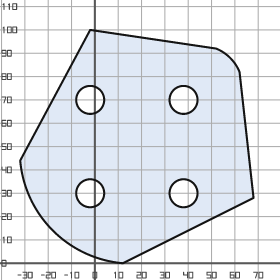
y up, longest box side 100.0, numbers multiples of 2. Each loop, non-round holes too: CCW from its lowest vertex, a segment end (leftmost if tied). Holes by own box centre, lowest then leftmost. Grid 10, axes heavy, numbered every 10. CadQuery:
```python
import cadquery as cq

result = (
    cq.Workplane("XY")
    .moveTo(12.0, 0.0)
    .lineTo(68.0, 28.0)
    .lineTo(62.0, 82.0)
    .threePointArc((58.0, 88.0), (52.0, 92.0))
    .lineTo(-2.0, 100.0)
    .lineTo(-32.0, 44.0)
    .threePointArc((-18.0, 14.0), (12.0, 0.0))
    .close()
    .moveTo(-2.0, 30.0)
    .circle(6.0)
    .moveTo(38.0, 30.0)
    .circle(6.0)
    .moveTo(-2.0, 70.0)
    .circle(6.0)
    .moveTo(38.0, 70.0)
    .circle(6.0)
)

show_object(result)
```